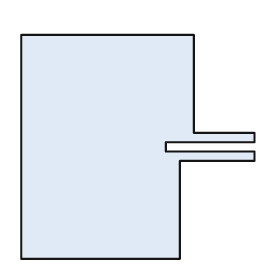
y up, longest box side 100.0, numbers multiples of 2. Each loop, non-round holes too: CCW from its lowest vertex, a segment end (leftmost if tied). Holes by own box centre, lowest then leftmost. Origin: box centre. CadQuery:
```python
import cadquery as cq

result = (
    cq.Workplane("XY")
    .moveTo(-50.0, -48.0)
    .lineTo(18.0, -48.0)
    .lineTo(18.0, -6.0)
    .lineTo(50.0, -6.0)
    .lineTo(50.0, -2.0)
    .lineTo(12.0, -2.0)
    .lineTo(12.0, 2.0)
    .lineTo(50.0, 2.0)
    .lineTo(50.0, 6.0)
    .lineTo(24.0, 6.0)
    .lineTo(24.0, 48.0)
    .lineTo(-50.0, 48.0)
    .close()
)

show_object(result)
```